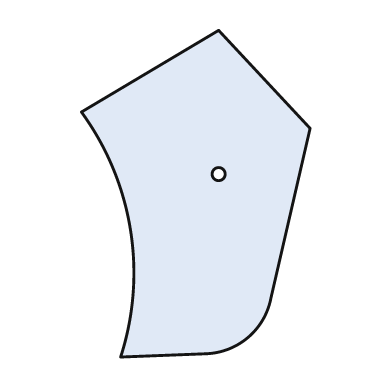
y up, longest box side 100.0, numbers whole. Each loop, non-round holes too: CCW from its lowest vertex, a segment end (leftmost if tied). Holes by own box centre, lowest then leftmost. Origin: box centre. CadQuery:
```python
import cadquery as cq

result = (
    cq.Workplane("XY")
    .moveTo(-23.0, -50.0)
    .lineTo(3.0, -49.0)
    .threePointArc((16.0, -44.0), (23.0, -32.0))
    .lineTo(35.0, 20.0)
    .lineTo(7.0, 50.0)
    .lineTo(-35.0, 25.0)
    .threePointArc((-20.0, -11.0), (-23.0, -50.0))
    .close()
    .moveTo(7.0, 6.0)
    .circle(2.0)
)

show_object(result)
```